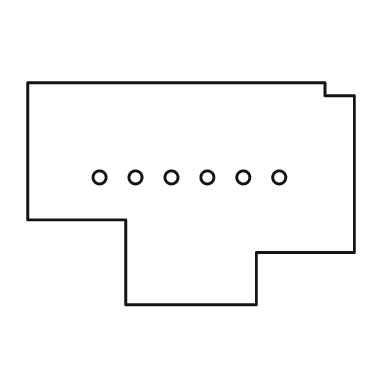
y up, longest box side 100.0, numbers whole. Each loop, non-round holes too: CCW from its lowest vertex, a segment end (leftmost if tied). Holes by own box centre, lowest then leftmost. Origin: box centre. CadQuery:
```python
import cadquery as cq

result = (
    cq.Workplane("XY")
    .moveTo(-20.0, -34.0)
    .lineTo(20.0, -34.0)
    .lineTo(20.0, -18.0)
    .lineTo(50.0, -18.0)
    .lineTo(50.0, 30.0)
    .lineTo(41.0, 30.0)
    .lineTo(41.0, 34.0)
    .lineTo(-50.0, 34.0)
    .lineTo(-50.0, -8.0)
    .lineTo(-20.0, -8.0)
    .close()
    .moveTo(-28.0, 5.0)
    .circle(2.0)
    .moveTo(-17.0, 5.0)
    .circle(2.0)
    .moveTo(-6.0, 5.0)
    .circle(2.0)
    .moveTo(5.0, 5.0)
    .circle(2.0)
    .moveTo(16.0, 5.0)
    .circle(2.0)
    .moveTo(27.0, 5.0)
    .circle(2.0)
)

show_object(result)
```